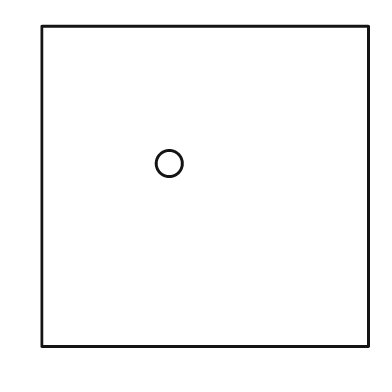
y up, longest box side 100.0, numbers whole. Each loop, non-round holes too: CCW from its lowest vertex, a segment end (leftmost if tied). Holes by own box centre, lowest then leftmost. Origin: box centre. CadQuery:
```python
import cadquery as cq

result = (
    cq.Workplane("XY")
    .moveTo(-50.0, -49.0)
    .lineTo(50.0, -49.0)
    .lineTo(50.0, 49.0)
    .lineTo(-50.0, 49.0)
    .close()
    .moveTo(-11.0, 7.0)
    .circle(4.0)
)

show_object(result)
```